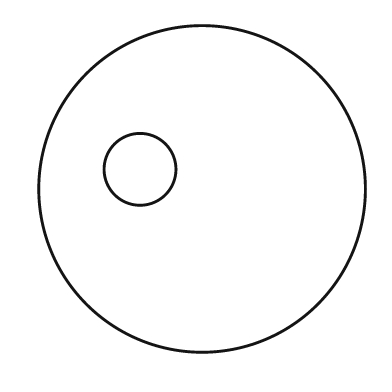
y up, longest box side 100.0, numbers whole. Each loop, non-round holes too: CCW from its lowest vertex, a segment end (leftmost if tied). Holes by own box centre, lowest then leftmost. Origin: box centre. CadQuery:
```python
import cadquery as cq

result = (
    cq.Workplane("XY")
    .moveTo(0.0, 0.0)
    .circle(50.0)
    .moveTo(-19.0, 6.0)
    .circle(11.0)
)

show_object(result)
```